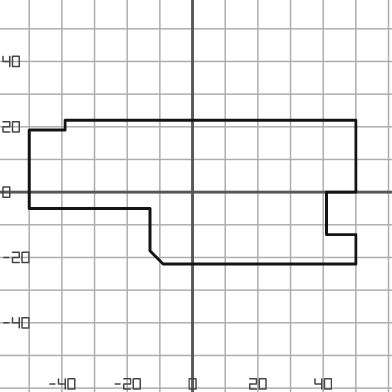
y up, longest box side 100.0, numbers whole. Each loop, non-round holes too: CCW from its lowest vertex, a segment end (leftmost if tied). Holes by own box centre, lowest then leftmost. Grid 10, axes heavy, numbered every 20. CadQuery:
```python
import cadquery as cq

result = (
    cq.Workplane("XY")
    .moveTo(-9.0, -22.0)
    .lineTo(50.0, -22.0)
    .lineTo(50.0, -13.0)
    .lineTo(41.0, -13.0)
    .lineTo(41.0, 0.0)
    .lineTo(50.0, 0.0)
    .lineTo(50.0, 22.0)
    .lineTo(-39.0, 22.0)
    .lineTo(-39.0, 19.0)
    .lineTo(-50.0, 19.0)
    .lineTo(-50.0, -5.0)
    .lineTo(-13.0, -5.0)
    .lineTo(-13.0, -18.0)
    .close()
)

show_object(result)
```